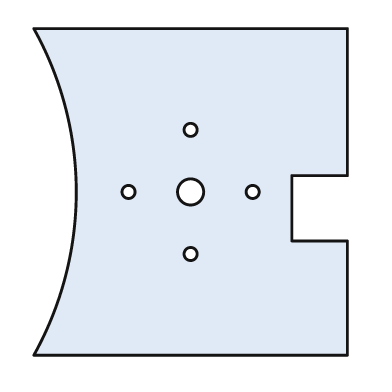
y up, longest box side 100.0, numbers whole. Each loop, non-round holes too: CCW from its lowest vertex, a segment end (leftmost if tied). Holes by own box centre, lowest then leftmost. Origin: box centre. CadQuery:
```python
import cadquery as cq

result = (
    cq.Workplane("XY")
    .moveTo(-48.0, -50.0)
    .lineTo(48.0, -50.0)
    .lineTo(48.0, -15.0)
    .lineTo(31.0, -15.0)
    .lineTo(31.0, 5.0)
    .lineTo(48.0, 5.0)
    .lineTo(48.0, 50.0)
    .lineTo(-48.0, 50.0)
    .threePointArc((-35.0, 0.0), (-48.0, -50.0))
    .close()
    .moveTo(0.0, -19.0)
    .circle(2.0)
    .moveTo(-19.0, 0.0)
    .circle(2.0)
    .moveTo(0.0, 0.0)
    .circle(4.0)
    .moveTo(19.0, 0.0)
    .circle(2.0)
    .moveTo(0.0, 19.0)
    .circle(2.0)
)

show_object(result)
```